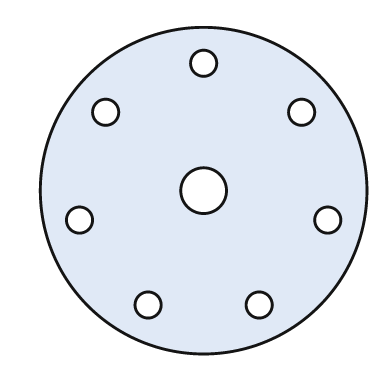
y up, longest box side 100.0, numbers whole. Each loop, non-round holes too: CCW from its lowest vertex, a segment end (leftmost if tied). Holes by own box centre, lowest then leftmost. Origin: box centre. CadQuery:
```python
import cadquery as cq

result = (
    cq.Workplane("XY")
    .moveTo(0.0, 0.0)
    .circle(50.0)
    .moveTo(-17.0, -35.0)
    .circle(4.0)
    .moveTo(17.0, -35.0)
    .circle(4.0)
    .moveTo(-38.0, -9.0)
    .circle(4.0)
    .moveTo(38.0, -9.0)
    .circle(4.0)
    .moveTo(0.0, 0.0)
    .circle(7.0)
    .moveTo(-30.0, 24.0)
    .circle(4.0)
    .moveTo(30.0, 24.0)
    .circle(4.0)
    .moveTo(0.0, 39.0)
    .circle(4.0)
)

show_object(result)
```